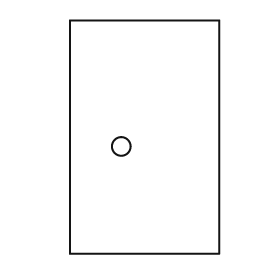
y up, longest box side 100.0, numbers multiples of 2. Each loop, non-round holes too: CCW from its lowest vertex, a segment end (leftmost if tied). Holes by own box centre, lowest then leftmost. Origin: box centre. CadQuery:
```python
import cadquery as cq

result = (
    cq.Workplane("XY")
    .moveTo(-32.0, -50.0)
    .lineTo(32.0, -50.0)
    .lineTo(32.0, 50.0)
    .lineTo(-32.0, 50.0)
    .close()
    .moveTo(-10.0, -4.0)
    .circle(4.0)
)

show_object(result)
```